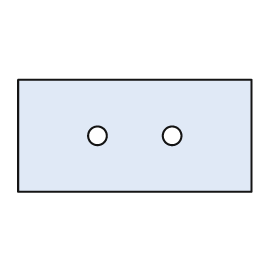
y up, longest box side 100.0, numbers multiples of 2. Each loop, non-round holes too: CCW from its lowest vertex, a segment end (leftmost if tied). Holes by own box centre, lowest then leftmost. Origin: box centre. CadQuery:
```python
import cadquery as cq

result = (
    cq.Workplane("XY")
    .moveTo(-50.0, -24.0)
    .lineTo(50.0, -24.0)
    .lineTo(50.0, 24.0)
    .lineTo(-50.0, 24.0)
    .close()
    .moveTo(-16.0, 0.0)
    .circle(4.0)
    .moveTo(16.0, 0.0)
    .circle(4.0)
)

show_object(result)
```